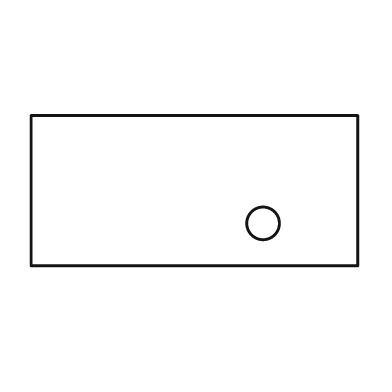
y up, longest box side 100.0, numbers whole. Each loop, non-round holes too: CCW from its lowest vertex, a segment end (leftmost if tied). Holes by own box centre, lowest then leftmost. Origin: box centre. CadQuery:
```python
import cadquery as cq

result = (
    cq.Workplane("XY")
    .moveTo(-50.0, -23.0)
    .lineTo(50.0, -23.0)
    .lineTo(50.0, 23.0)
    .lineTo(-50.0, 23.0)
    .close()
    .moveTo(21.0, -10.0)
    .circle(5.0)
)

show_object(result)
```